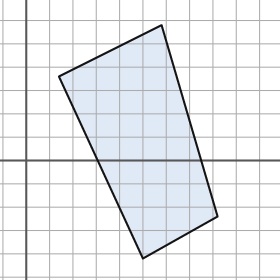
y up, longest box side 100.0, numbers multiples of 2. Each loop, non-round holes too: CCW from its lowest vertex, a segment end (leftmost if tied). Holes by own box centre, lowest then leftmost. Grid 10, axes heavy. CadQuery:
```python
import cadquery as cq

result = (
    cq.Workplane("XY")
    .moveTo(50.0, -42.0)
    .lineTo(82.0, -24.0)
    .lineTo(58.0, 58.0)
    .lineTo(14.0, 36.0)
    .close()
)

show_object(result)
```